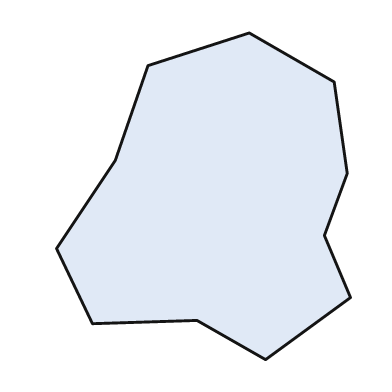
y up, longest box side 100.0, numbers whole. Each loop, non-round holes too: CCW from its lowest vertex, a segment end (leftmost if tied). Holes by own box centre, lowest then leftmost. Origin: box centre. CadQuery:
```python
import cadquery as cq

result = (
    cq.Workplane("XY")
    .moveTo(19.0, -50.0)
    .lineTo(45.0, -31.0)
    .lineTo(37.0, -12.0)
    .lineTo(44.0, 7.0)
    .lineTo(40.0, 35.0)
    .lineTo(14.0, 50.0)
    .lineTo(-17.0, 40.0)
    .lineTo(-27.0, 11.0)
    .lineTo(-45.0, -16.0)
    .lineTo(-34.0, -39.0)
    .lineTo(-2.0, -38.0)
    .close()
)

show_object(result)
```